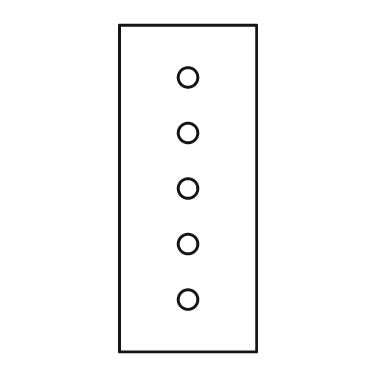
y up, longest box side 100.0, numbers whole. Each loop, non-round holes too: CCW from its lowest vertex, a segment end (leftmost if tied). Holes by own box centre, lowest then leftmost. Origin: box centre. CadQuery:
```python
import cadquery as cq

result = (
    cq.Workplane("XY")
    .moveTo(-21.0, -50.0)
    .lineTo(21.0, -50.0)
    .lineTo(21.0, 50.0)
    .lineTo(-21.0, 50.0)
    .close()
    .moveTo(0.0, -34.0)
    .circle(3.0)
    .moveTo(0.0, -17.0)
    .circle(3.0)
    .moveTo(0.0, 0.0)
    .circle(3.0)
    .moveTo(0.0, 17.0)
    .circle(3.0)
    .moveTo(0.0, 34.0)
    .circle(3.0)
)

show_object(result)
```